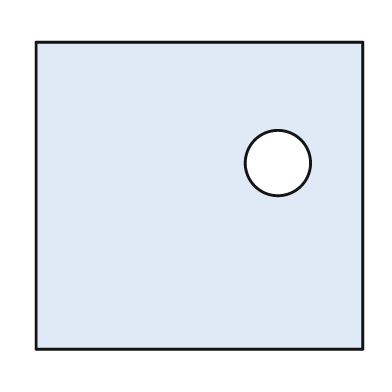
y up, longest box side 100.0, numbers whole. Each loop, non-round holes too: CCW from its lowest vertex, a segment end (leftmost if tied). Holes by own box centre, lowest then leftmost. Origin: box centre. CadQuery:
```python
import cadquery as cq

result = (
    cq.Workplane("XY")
    .moveTo(-50.0, -47.0)
    .lineTo(50.0, -47.0)
    .lineTo(50.0, 47.0)
    .lineTo(-50.0, 47.0)
    .close()
    .moveTo(24.0, 10.0)
    .circle(10.0)
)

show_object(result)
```